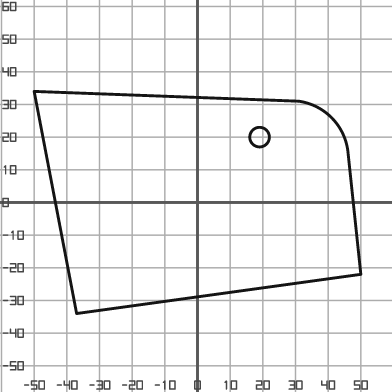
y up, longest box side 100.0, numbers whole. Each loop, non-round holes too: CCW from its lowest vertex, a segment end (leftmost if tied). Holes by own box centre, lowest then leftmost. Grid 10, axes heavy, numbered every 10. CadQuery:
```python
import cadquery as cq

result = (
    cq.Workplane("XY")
    .moveTo(-37.0, -34.0)
    .lineTo(50.0, -22.0)
    .lineTo(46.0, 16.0)
    .threePointArc((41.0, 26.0), (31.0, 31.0))
    .lineTo(-50.0, 34.0)
    .close()
    .moveTo(19.0, 20.0)
    .circle(3.0)
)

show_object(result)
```